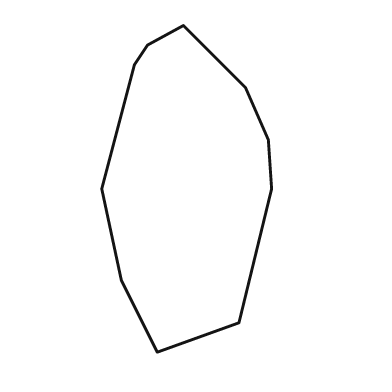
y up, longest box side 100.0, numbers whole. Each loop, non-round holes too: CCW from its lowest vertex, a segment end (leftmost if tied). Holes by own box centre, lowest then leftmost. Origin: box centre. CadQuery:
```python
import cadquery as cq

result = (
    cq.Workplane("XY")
    .moveTo(-9.0, -50.0)
    .lineTo(16.0, -41.0)
    .lineTo(26.0, 0.0)
    .lineTo(25.0, 15.0)
    .lineTo(18.0, 31.0)
    .lineTo(-1.0, 50.0)
    .lineTo(-12.0, 44.0)
    .lineTo(-16.0, 38.0)
    .lineTo(-26.0, 0.0)
    .lineTo(-20.0, -28.0)
    .close()
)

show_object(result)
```